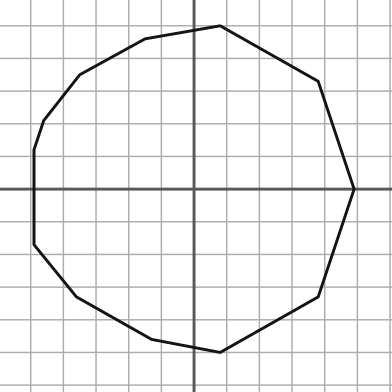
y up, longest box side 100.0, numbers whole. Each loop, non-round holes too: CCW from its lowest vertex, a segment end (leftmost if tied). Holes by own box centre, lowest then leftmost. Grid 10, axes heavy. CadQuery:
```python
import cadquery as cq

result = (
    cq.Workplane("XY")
    .moveTo(8.0, -50.0)
    .lineTo(38.0, -33.0)
    .lineTo(49.0, 0.0)
    .lineTo(38.0, 33.0)
    .lineTo(8.0, 50.0)
    .lineTo(-15.0, 46.0)
    .lineTo(-35.0, 35.0)
    .lineTo(-46.0, 21.0)
    .lineTo(-49.0, 12.0)
    .lineTo(-49.0, -17.0)
    .lineTo(-36.0, -33.0)
    .lineTo(-13.0, -46.0)
    .close()
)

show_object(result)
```